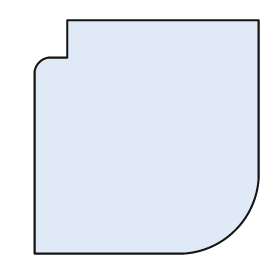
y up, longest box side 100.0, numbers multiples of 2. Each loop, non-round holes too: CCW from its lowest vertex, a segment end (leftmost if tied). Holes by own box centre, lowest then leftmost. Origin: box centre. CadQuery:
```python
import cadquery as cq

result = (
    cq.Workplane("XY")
    .moveTo(-48.0, -50.0)
    .lineTo(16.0, -50.0)
    .threePointArc((38.0, -40.0), (48.0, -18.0))
    .lineTo(48.0, 50.0)
    .lineTo(-34.0, 50.0)
    .lineTo(-34.0, 34.0)
    .lineTo(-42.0, 34.0)
    .threePointArc((-46.0, 32.0), (-48.0, 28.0))
    .close()
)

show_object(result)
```